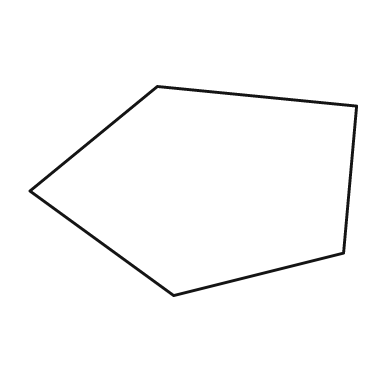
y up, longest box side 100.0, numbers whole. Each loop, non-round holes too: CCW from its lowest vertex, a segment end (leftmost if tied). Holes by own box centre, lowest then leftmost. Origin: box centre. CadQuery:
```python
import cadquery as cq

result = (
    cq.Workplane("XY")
    .moveTo(-6.0, -32.0)
    .lineTo(46.0, -19.0)
    .lineTo(50.0, 26.0)
    .lineTo(-11.0, 32.0)
    .lineTo(-50.0, 0.0)
    .close()
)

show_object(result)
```